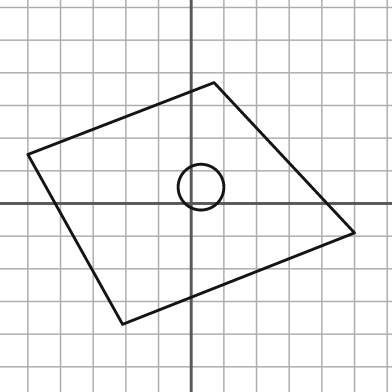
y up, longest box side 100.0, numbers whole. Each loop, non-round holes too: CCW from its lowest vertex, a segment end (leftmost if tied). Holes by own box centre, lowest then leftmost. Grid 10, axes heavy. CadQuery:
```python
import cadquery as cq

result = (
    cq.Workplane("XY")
    .moveTo(-21.0, -37.0)
    .lineTo(50.0, -9.0)
    .lineTo(7.0, 37.0)
    .lineTo(-50.0, 15.0)
    .close()
    .moveTo(3.0, 5.0)
    .circle(7.0)
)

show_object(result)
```